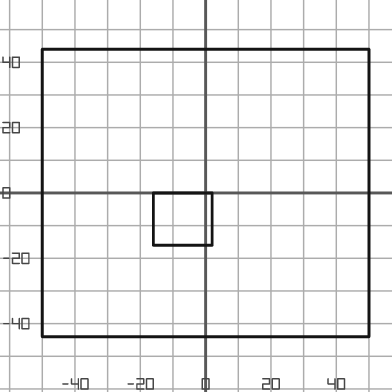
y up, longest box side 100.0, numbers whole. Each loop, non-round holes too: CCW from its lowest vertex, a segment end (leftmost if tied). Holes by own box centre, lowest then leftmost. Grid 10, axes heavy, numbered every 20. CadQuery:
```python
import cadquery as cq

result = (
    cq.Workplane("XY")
    .moveTo(-50.0, -44.0)
    .lineTo(50.0, -44.0)
    .lineTo(50.0, 44.0)
    .lineTo(-50.0, 44.0)
    .close()
    .moveTo(-16.0, -16.0)
    .lineTo(2.0, -16.0)
    .lineTo(2.0, 0.0)
    .lineTo(-16.0, 0.0)
    .close()
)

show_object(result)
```